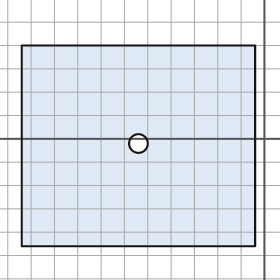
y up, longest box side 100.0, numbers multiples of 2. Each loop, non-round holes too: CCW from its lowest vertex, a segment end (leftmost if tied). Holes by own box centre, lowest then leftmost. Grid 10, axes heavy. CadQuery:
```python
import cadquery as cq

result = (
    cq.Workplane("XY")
    .moveTo(-104.0, -46.0)
    .lineTo(-4.0, -46.0)
    .lineTo(-4.0, 40.0)
    .lineTo(-104.0, 40.0)
    .close()
    .moveTo(-54.0, -2.0)
    .circle(4.0)
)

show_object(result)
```